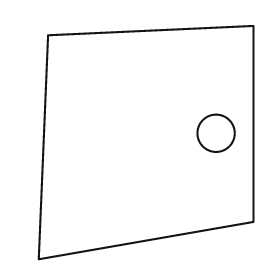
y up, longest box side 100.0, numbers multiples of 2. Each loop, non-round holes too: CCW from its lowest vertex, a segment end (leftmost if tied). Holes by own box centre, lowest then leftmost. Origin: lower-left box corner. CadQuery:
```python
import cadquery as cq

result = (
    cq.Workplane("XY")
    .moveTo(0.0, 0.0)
    .lineTo(92.0, 16.0)
    .lineTo(92.0, 100.0)
    .lineTo(4.0, 96.0)
    .close()
    .moveTo(76.0, 54.0)
    .circle(8.0)
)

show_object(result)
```